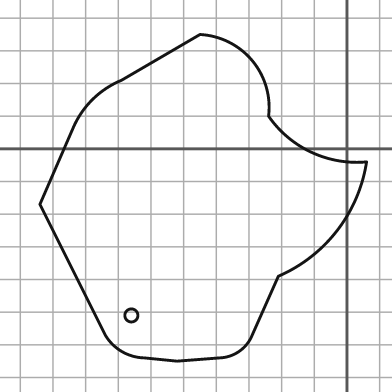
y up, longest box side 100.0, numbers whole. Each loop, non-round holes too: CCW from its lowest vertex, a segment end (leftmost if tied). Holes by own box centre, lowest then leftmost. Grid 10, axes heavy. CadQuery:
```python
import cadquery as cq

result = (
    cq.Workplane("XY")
    .moveTo(-52.0, -65.0)
    .lineTo(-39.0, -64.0)
    .threePointArc((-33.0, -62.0), (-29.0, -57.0))
    .lineTo(-21.0, -39.0)
    .threePointArc((-3.0, -25.0), (6.0, -4.0))
    .threePointArc((-11.0, -1.0), (-24.0, 10.0))
    .threePointArc((-29.0, 27.0), (-45.0, 35.0))
    .lineTo(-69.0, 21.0)
    .threePointArc((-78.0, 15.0), (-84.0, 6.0))
    .lineTo(-94.0, -17.0)
    .lineTo(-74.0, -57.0)
    .threePointArc((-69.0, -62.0), (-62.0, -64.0))
    .close()
    .moveTo(-66.0, -51.0)
    .circle(2.0)
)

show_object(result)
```